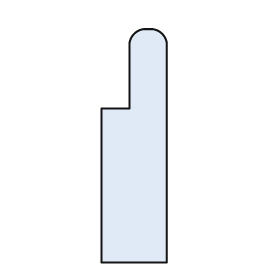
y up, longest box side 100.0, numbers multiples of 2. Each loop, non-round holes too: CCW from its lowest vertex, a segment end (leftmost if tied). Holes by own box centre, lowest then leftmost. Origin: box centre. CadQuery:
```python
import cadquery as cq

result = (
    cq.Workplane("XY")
    .moveTo(-14.0, -50.0)
    .lineTo(14.0, -50.0)
    .lineTo(14.0, 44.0)
    .threePointArc((12.0, 48.0), (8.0, 50.0))
    .lineTo(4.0, 50.0)
    .threePointArc((0.0, 48.0), (-2.0, 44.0))
    .lineTo(-2.0, 16.0)
    .lineTo(-14.0, 16.0)
    .close()
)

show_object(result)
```